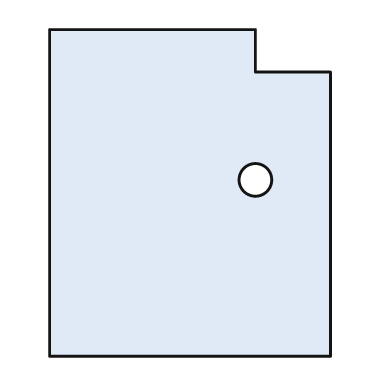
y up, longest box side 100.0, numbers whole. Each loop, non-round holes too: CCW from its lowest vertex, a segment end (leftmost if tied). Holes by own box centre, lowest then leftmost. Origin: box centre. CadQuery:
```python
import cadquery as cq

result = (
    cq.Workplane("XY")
    .moveTo(-43.0, -50.0)
    .lineTo(43.0, -50.0)
    .lineTo(43.0, 37.0)
    .lineTo(20.0, 37.0)
    .lineTo(20.0, 50.0)
    .lineTo(-43.0, 50.0)
    .close()
    .moveTo(20.0, 4.0)
    .circle(5.0)
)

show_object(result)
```